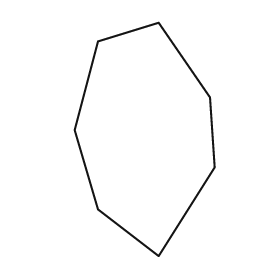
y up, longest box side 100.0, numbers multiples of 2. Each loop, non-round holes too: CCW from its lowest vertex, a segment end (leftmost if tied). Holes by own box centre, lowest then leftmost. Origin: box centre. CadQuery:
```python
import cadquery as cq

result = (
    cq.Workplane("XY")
    .moveTo(6.0, -50.0)
    .lineTo(30.0, -12.0)
    .lineTo(28.0, 18.0)
    .lineTo(6.0, 50.0)
    .lineTo(-20.0, 42.0)
    .lineTo(-30.0, 4.0)
    .lineTo(-20.0, -30.0)
    .close()
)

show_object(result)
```